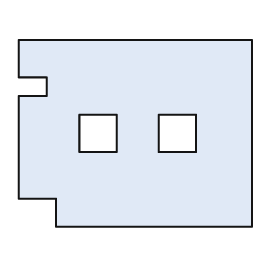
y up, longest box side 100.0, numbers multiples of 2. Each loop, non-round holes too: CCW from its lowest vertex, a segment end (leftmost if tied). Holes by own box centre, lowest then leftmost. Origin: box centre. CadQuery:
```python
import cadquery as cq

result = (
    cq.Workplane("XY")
    .moveTo(-34.0, -40.0)
    .lineTo(50.0, -40.0)
    .lineTo(50.0, 40.0)
    .lineTo(-50.0, 40.0)
    .lineTo(-50.0, 24.0)
    .lineTo(-38.0, 24.0)
    .lineTo(-38.0, 16.0)
    .lineTo(-50.0, 16.0)
    .lineTo(-50.0, -28.0)
    .lineTo(-34.0, -28.0)
    .close()
    .moveTo(-24.0, -8.0)
    .lineTo(-8.0, -8.0)
    .lineTo(-8.0, 8.0)
    .lineTo(-24.0, 8.0)
    .close()
    .moveTo(10.0, -8.0)
    .lineTo(26.0, -8.0)
    .lineTo(26.0, 8.0)
    .lineTo(10.0, 8.0)
    .close()
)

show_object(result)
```